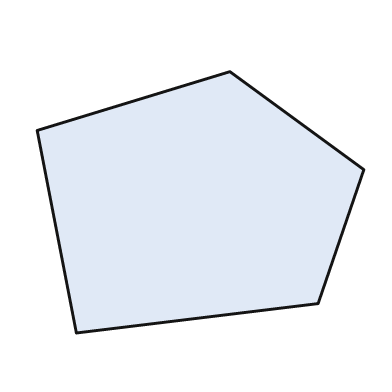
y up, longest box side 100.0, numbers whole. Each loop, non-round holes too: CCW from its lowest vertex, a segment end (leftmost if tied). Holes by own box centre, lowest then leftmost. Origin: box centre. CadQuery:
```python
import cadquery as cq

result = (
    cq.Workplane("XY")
    .moveTo(-38.0, -40.0)
    .lineTo(36.0, -31.0)
    .lineTo(50.0, 10.0)
    .lineTo(9.0, 40.0)
    .lineTo(-50.0, 22.0)
    .close()
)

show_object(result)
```